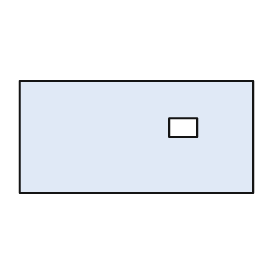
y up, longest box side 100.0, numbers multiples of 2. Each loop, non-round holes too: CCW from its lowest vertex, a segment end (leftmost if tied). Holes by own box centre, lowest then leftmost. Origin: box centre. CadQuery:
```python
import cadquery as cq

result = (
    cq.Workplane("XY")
    .moveTo(-50.0, -24.0)
    .lineTo(50.0, -24.0)
    .lineTo(50.0, 24.0)
    .lineTo(-50.0, 24.0)
    .close()
    .moveTo(14.0, 0.0)
    .lineTo(26.0, 0.0)
    .lineTo(26.0, 8.0)
    .lineTo(14.0, 8.0)
    .close()
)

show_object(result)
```